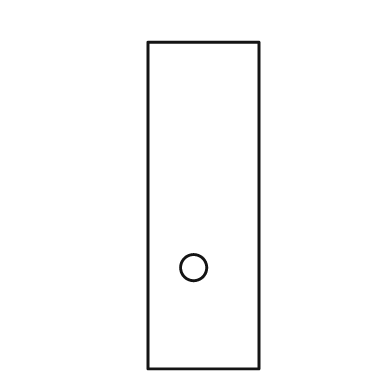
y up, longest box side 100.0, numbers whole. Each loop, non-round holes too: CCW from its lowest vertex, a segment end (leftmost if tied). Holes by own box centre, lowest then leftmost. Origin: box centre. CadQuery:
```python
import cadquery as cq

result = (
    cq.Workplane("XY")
    .moveTo(-17.0, -50.0)
    .lineTo(17.0, -50.0)
    .lineTo(17.0, 50.0)
    .lineTo(-17.0, 50.0)
    .close()
    .moveTo(-3.0, -19.0)
    .circle(4.0)
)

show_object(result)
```